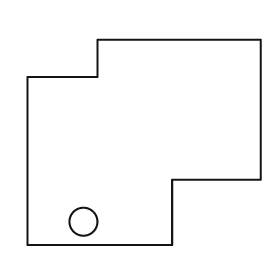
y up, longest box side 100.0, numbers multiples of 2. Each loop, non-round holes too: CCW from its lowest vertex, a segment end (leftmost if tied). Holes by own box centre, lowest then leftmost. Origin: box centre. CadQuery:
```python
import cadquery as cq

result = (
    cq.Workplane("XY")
    .moveTo(-50.0, -44.0)
    .lineTo(12.0, -44.0)
    .lineTo(12.0, -16.0)
    .lineTo(50.0, -16.0)
    .lineTo(50.0, 44.0)
    .lineTo(-20.0, 44.0)
    .lineTo(-20.0, 28.0)
    .lineTo(-50.0, 28.0)
    .close()
    .moveTo(-26.0, -34.0)
    .circle(6.0)
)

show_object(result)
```